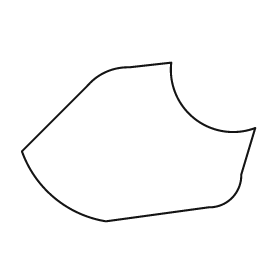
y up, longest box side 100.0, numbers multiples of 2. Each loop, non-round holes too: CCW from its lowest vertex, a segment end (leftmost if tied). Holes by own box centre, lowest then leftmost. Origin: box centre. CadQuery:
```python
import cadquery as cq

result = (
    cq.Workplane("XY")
    .moveTo(-14.0, -34.0)
    .lineTo(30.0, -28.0)
    .threePointArc((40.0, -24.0), (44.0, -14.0))
    .lineTo(50.0, 6.0)
    .threePointArc((24.0, 10.0), (14.0, 34.0))
    .lineTo(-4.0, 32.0)
    .threePointArc((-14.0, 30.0), (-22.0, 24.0))
    .lineTo(-50.0, -4.0)
    .threePointArc((-36.0, -24.0), (-14.0, -34.0))
    .close()
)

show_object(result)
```